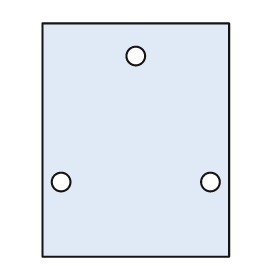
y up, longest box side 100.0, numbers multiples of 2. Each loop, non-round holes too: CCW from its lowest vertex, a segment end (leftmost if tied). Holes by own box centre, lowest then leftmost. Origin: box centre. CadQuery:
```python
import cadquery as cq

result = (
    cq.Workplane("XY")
    .moveTo(-40.0, -50.0)
    .lineTo(40.0, -50.0)
    .lineTo(40.0, 50.0)
    .lineTo(-40.0, 50.0)
    .close()
    .moveTo(-32.0, -18.0)
    .circle(4.0)
    .moveTo(32.0, -18.0)
    .circle(4.0)
    .moveTo(0.0, 36.0)
    .circle(4.0)
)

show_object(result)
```